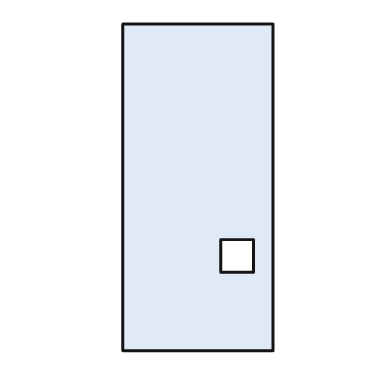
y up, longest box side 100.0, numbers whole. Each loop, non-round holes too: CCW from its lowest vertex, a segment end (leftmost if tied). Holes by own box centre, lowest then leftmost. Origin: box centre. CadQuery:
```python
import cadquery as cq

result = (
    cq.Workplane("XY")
    .moveTo(-23.0, -50.0)
    .lineTo(23.0, -50.0)
    .lineTo(23.0, 50.0)
    .lineTo(-23.0, 50.0)
    .close()
    .moveTo(7.0, -26.0)
    .lineTo(17.0, -26.0)
    .lineTo(17.0, -16.0)
    .lineTo(7.0, -16.0)
    .close()
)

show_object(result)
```